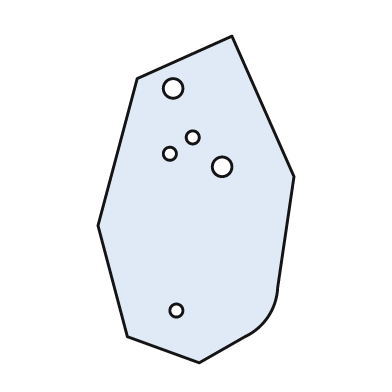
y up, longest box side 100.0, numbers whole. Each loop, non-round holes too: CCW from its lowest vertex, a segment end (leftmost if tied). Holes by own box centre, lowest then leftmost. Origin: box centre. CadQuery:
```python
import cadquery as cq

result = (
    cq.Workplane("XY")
    .moveTo(1.0, -50.0)
    .lineTo(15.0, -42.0)
    .threePointArc((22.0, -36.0), (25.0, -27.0))
    .lineTo(30.0, 7.0)
    .lineTo(11.0, 50.0)
    .lineTo(-18.0, 37.0)
    .lineTo(-30.0, -8.0)
    .lineTo(-21.0, -42.0)
    .close()
    .moveTo(-6.0, -34.0)
    .circle(2.0)
    .moveTo(8.0, 10.0)
    .circle(3.0)
    .moveTo(-8.0, 14.0)
    .circle(2.0)
    .moveTo(-1.0, 19.0)
    .circle(2.0)
    .moveTo(-7.0, 34.0)
    .circle(3.0)
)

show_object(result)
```